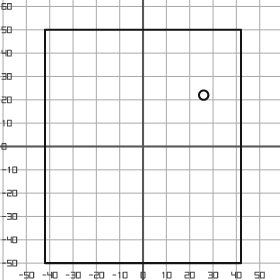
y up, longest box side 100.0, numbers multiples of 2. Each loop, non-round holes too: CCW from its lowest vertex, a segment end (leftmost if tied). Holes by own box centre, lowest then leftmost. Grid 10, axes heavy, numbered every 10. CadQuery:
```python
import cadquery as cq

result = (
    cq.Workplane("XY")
    .moveTo(-42.0, -50.0)
    .lineTo(42.0, -50.0)
    .lineTo(42.0, 50.0)
    .lineTo(-42.0, 50.0)
    .close()
    .moveTo(26.0, 22.0)
    .circle(2.0)
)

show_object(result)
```